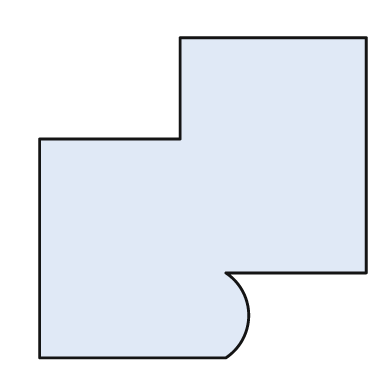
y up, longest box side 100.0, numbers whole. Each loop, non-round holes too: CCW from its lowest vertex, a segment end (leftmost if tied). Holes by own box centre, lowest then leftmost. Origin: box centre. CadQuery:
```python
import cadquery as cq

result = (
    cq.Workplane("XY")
    .moveTo(-50.0, -49.0)
    .lineTo(7.0, -49.0)
    .threePointArc((14.0, -36.0), (7.0, -23.0))
    .lineTo(50.0, -23.0)
    .lineTo(50.0, 49.0)
    .lineTo(-7.0, 49.0)
    .lineTo(-7.0, 18.0)
    .lineTo(-50.0, 18.0)
    .close()
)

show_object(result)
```